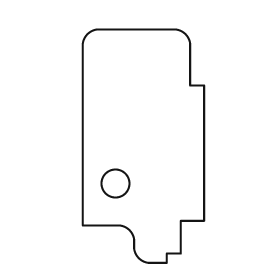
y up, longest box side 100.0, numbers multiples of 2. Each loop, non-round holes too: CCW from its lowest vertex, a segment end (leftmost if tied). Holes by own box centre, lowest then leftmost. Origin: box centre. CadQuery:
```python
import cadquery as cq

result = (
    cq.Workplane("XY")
    .moveTo(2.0, -50.0)
    .lineTo(10.0, -50.0)
    .lineTo(10.0, -46.0)
    .lineTo(16.0, -46.0)
    .lineTo(16.0, -32.0)
    .lineTo(26.0, -32.0)
    .lineTo(26.0, 26.0)
    .lineTo(20.0, 26.0)
    .lineTo(20.0, 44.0)
    .threePointArc((18.0, 48.0), (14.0, 50.0))
    .lineTo(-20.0, 50.0)
    .threePointArc((-24.0, 48.0), (-26.0, 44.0))
    .lineTo(-26.0, -34.0)
    .lineTo(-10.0, -34.0)
    .threePointArc((-6.0, -36.0), (-4.0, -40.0))
    .lineTo(-4.0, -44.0)
    .threePointArc((-2.0, -48.0), (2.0, -50.0))
    .close()
    .moveTo(-12.0, -16.0)
    .circle(6.0)
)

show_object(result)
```